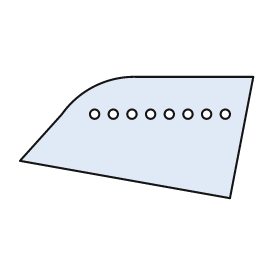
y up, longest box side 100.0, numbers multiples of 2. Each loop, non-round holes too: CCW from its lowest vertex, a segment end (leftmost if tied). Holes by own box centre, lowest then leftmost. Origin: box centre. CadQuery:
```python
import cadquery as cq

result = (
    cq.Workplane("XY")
    .moveTo(40.0, -26.0)
    .lineTo(50.0, 26.0)
    .lineTo(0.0, 26.0)
    .threePointArc((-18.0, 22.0), (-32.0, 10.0))
    .lineTo(-50.0, -10.0)
    .close()
    .moveTo(-18.0, 10.0)
    .circle(2.0)
    .moveTo(-10.0, 10.0)
    .circle(2.0)
    .moveTo(-2.0, 10.0)
    .circle(2.0)
    .moveTo(6.0, 10.0)
    .circle(2.0)
    .moveTo(14.0, 10.0)
    .circle(2.0)
    .moveTo(22.0, 10.0)
    .circle(2.0)
    .moveTo(30.0, 10.0)
    .circle(2.0)
    .moveTo(38.0, 10.0)
    .circle(2.0)
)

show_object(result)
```